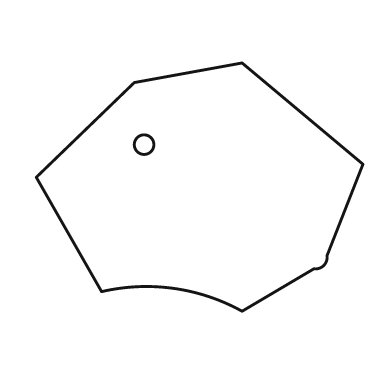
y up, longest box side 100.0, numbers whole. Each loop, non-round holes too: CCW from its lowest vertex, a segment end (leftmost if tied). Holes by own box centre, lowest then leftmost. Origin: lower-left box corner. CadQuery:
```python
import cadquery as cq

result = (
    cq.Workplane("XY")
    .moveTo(63.0, 0.0)
    .lineTo(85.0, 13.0)
    .threePointArc((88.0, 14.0), (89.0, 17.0))
    .lineTo(100.0, 45.0)
    .lineTo(63.0, 76.0)
    .lineTo(30.0, 70.0)
    .lineTo(0.0, 41.0)
    .lineTo(20.0, 6.0)
    .threePointArc((42.0, 7.0), (63.0, 0.0))
    .close()
    .moveTo(33.0, 51.0)
    .circle(3.0)
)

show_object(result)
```